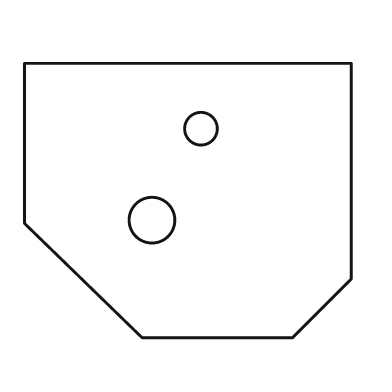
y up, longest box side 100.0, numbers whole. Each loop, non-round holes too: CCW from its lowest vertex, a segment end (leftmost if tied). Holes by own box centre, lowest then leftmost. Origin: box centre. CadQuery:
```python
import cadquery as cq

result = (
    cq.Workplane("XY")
    .moveTo(-14.0, -42.0)
    .lineTo(32.0, -42.0)
    .lineTo(50.0, -24.0)
    .lineTo(50.0, 42.0)
    .lineTo(-50.0, 42.0)
    .lineTo(-50.0, -7.0)
    .close()
    .moveTo(-11.0, -6.0)
    .circle(7.0)
    .moveTo(4.0, 22.0)
    .circle(5.0)
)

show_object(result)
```